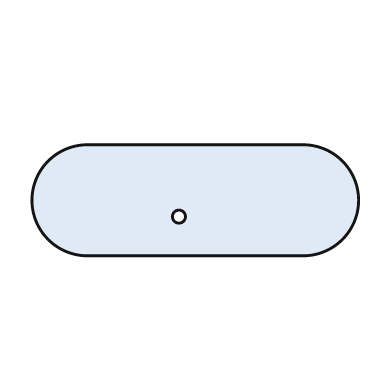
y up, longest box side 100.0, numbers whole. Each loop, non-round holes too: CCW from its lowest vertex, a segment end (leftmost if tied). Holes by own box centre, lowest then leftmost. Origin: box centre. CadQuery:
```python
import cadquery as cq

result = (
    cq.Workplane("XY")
    .moveTo(-33.0, -17.0)
    .lineTo(33.0, -17.0)
    .threePointArc((50.0, 0.0), (33.0, 17.0))
    .lineTo(-33.0, 17.0)
    .threePointArc((-50.0, 0.0), (-33.0, -17.0))
    .close()
    .moveTo(-5.0, -5.0)
    .circle(2.0)
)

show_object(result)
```